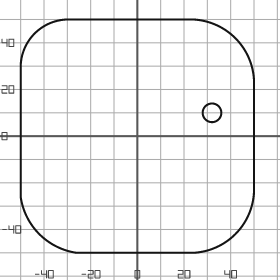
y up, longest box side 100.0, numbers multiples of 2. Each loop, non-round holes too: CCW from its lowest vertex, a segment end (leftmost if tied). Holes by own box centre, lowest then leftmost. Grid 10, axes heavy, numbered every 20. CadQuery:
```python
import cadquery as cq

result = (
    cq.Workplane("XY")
    .moveTo(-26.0, -50.0)
    .lineTo(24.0, -50.0)
    .threePointArc((42.0, -42.0), (50.0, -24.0))
    .lineTo(50.0, 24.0)
    .threePointArc((42.0, 42.0), (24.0, 50.0))
    .lineTo(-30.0, 50.0)
    .threePointArc((-44.0, 44.0), (-50.0, 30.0))
    .lineTo(-50.0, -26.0)
    .threePointArc((-42.0, -42.0), (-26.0, -50.0))
    .close()
    .moveTo(32.0, 10.0)
    .circle(4.0)
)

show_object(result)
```